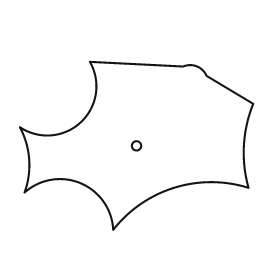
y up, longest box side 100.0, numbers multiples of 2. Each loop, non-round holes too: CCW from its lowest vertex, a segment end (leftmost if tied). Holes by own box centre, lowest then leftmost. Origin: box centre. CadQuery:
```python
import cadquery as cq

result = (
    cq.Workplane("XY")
    .moveTo(-10.0, -36.0)
    .threePointArc((16.0, -18.0), (48.0, -18.0))
    .threePointArc((46.0, 0.0), (50.0, 18.0))
    .lineTo(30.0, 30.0)
    .threePointArc((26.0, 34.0), (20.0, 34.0))
    .lineTo(-20.0, 36.0)
    .threePointArc((-24.0, 10.0), (-50.0, 8.0))
    .threePointArc((-46.0, -6.0), (-48.0, -20.0))
    .threePointArc((-24.0, -16.0), (-10.0, -36.0))
    .close()
    .moveTo(0.0, 0.0)
    .circle(2.0)
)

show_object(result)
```